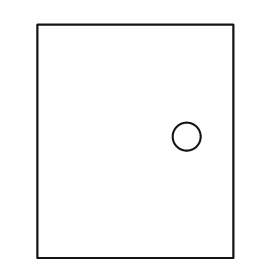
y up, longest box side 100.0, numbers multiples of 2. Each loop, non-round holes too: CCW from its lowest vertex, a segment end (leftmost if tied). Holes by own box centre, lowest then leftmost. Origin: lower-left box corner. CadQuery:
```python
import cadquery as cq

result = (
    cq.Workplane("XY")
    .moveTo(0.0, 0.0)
    .lineTo(84.0, 0.0)
    .lineTo(84.0, 100.0)
    .lineTo(0.0, 100.0)
    .close()
    .moveTo(64.0, 52.0)
    .circle(6.0)
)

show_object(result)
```